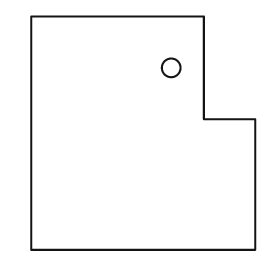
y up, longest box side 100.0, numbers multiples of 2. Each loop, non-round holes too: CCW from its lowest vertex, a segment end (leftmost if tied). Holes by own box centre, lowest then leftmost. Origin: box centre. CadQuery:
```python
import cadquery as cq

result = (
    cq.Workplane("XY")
    .moveTo(-48.0, -50.0)
    .lineTo(48.0, -50.0)
    .lineTo(48.0, 6.0)
    .lineTo(26.0, 6.0)
    .lineTo(26.0, 50.0)
    .lineTo(-48.0, 50.0)
    .close()
    .moveTo(12.0, 28.0)
    .circle(4.0)
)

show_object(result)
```